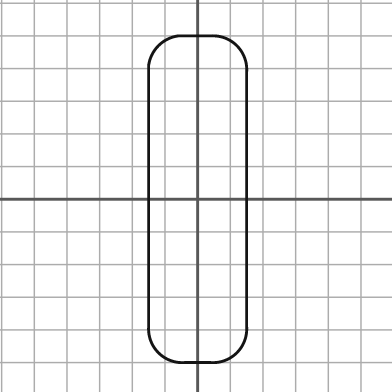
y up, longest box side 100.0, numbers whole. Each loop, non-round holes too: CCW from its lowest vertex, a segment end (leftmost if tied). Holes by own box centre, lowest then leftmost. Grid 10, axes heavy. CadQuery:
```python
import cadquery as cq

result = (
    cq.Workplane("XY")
    .moveTo(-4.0, -50.0)
    .lineTo(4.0, -50.0)
    .threePointArc((12.0, -47.0), (15.0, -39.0))
    .lineTo(15.0, 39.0)
    .threePointArc((12.0, 47.0), (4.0, 50.0))
    .lineTo(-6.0, 50.0)
    .threePointArc((-12.0, 47.0), (-15.0, 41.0))
    .lineTo(-15.0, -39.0)
    .threePointArc((-12.0, -47.0), (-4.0, -50.0))
    .close()
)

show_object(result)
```